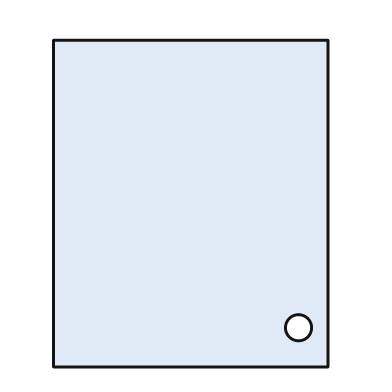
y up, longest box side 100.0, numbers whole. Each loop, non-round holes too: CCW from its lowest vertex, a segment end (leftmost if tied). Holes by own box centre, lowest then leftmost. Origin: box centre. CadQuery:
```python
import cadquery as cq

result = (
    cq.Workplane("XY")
    .moveTo(-42.0, -50.0)
    .lineTo(42.0, -50.0)
    .lineTo(42.0, 50.0)
    .lineTo(-42.0, 50.0)
    .close()
    .moveTo(33.0, -38.0)
    .circle(4.0)
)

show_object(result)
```